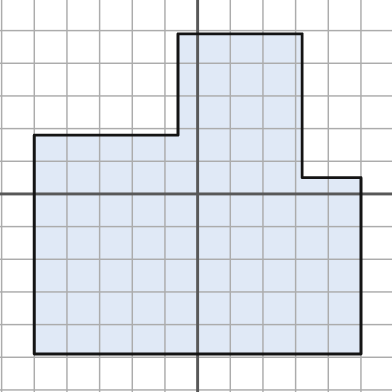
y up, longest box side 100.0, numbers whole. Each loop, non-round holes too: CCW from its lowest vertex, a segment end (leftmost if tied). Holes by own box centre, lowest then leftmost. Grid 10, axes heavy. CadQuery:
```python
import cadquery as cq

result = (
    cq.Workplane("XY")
    .moveTo(-50.0, -49.0)
    .lineTo(50.0, -49.0)
    .lineTo(50.0, 5.0)
    .lineTo(32.0, 5.0)
    .lineTo(32.0, 49.0)
    .lineTo(-6.0, 49.0)
    .lineTo(-6.0, 18.0)
    .lineTo(-50.0, 18.0)
    .close()
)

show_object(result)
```